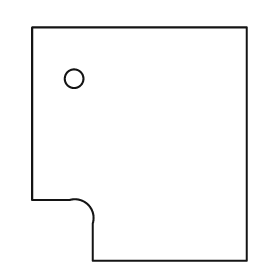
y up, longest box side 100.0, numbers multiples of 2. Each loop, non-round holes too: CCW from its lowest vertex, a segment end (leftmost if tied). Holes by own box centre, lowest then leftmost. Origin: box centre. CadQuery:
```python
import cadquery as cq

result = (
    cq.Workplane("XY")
    .moveTo(-20.0, -50.0)
    .lineTo(46.0, -50.0)
    .lineTo(46.0, 50.0)
    .lineTo(-46.0, 50.0)
    .lineTo(-46.0, -24.0)
    .lineTo(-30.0, -24.0)
    .threePointArc((-22.0, -26.0), (-20.0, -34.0))
    .close()
    .moveTo(-28.0, 28.0)
    .circle(4.0)
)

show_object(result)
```